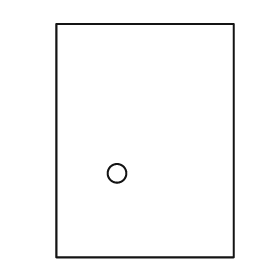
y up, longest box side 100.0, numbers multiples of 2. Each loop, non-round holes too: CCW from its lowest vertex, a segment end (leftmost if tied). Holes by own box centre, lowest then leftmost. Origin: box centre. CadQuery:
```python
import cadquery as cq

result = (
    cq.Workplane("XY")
    .moveTo(-38.0, -50.0)
    .lineTo(38.0, -50.0)
    .lineTo(38.0, 50.0)
    .lineTo(-38.0, 50.0)
    .close()
    .moveTo(-12.0, -14.0)
    .circle(4.0)
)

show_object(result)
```